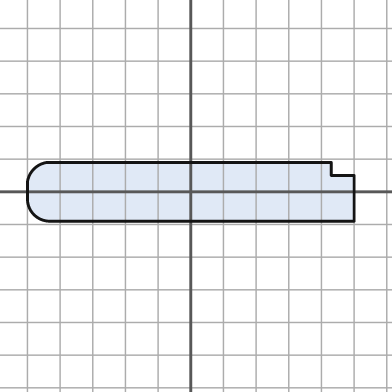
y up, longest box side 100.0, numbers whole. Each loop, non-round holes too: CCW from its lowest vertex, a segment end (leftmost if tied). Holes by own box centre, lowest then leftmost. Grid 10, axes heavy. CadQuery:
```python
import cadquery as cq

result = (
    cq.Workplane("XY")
    .moveTo(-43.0, -9.0)
    .lineTo(50.0, -9.0)
    .lineTo(50.0, 5.0)
    .lineTo(43.0, 5.0)
    .lineTo(43.0, 9.0)
    .lineTo(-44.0, 9.0)
    .threePointArc((-48.0, 7.0), (-50.0, 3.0))
    .lineTo(-50.0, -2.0)
    .threePointArc((-48.0, -7.0), (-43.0, -9.0))
    .close()
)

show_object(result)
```